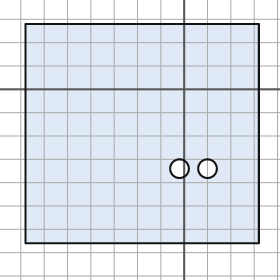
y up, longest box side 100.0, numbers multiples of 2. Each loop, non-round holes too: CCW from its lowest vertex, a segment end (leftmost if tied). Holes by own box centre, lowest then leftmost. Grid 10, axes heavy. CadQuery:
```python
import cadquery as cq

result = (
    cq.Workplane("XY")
    .moveTo(-68.0, -66.0)
    .lineTo(32.0, -66.0)
    .lineTo(32.0, 28.0)
    .lineTo(-68.0, 28.0)
    .close()
    .moveTo(-2.0, -34.0)
    .circle(4.0)
    .moveTo(10.0, -34.0)
    .circle(4.0)
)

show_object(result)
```